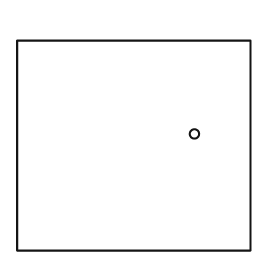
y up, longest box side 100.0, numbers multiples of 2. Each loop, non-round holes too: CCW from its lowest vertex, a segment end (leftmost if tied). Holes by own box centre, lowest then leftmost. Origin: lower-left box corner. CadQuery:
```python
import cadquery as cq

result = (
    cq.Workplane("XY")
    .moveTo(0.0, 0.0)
    .lineTo(100.0, 0.0)
    .lineTo(100.0, 90.0)
    .lineTo(0.0, 90.0)
    .close()
    .moveTo(76.0, 50.0)
    .circle(2.0)
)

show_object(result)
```